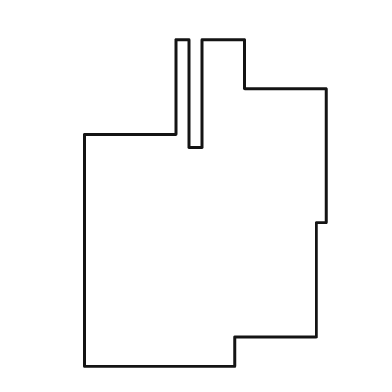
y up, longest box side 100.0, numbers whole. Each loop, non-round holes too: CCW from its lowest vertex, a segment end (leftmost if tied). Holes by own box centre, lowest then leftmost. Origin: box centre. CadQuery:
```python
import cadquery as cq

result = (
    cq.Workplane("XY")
    .moveTo(-37.0, -50.0)
    .lineTo(9.0, -50.0)
    .lineTo(9.0, -41.0)
    .lineTo(34.0, -41.0)
    .lineTo(34.0, -6.0)
    .lineTo(37.0, -6.0)
    .lineTo(37.0, 35.0)
    .lineTo(12.0, 35.0)
    .lineTo(12.0, 50.0)
    .lineTo(-1.0, 50.0)
    .lineTo(-1.0, 17.0)
    .lineTo(-5.0, 17.0)
    .lineTo(-5.0, 50.0)
    .lineTo(-9.0, 50.0)
    .lineTo(-9.0, 21.0)
    .lineTo(-37.0, 21.0)
    .close()
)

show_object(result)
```